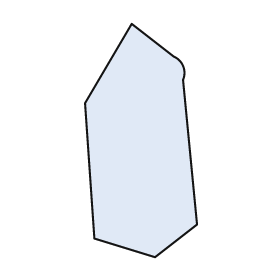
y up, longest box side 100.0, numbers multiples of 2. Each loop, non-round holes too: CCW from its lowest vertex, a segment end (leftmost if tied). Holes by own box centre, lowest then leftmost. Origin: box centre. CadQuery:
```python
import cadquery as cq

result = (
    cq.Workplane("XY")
    .moveTo(6.0, -50.0)
    .lineTo(24.0, -36.0)
    .lineTo(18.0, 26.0)
    .threePointArc((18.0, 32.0), (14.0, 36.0))
    .lineTo(-4.0, 50.0)
    .lineTo(-24.0, 16.0)
    .lineTo(-20.0, -42.0)
    .close()
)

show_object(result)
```